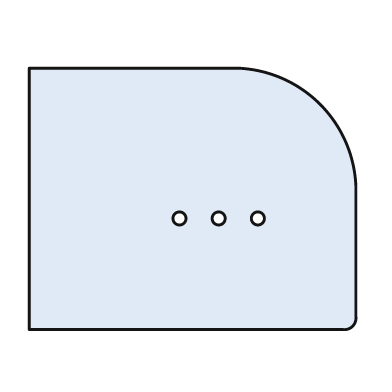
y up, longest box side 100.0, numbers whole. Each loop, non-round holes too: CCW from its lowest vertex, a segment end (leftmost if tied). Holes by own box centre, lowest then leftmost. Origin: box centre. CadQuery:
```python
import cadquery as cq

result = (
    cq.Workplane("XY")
    .moveTo(-50.0, -40.0)
    .lineTo(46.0, -40.0)
    .threePointArc((49.0, -39.0), (50.0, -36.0))
    .lineTo(50.0, 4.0)
    .threePointArc((39.0, 29.0), (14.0, 40.0))
    .lineTo(-50.0, 40.0)
    .close()
    .moveTo(-4.0, -6.0)
    .circle(2.0)
    .moveTo(8.0, -6.0)
    .circle(2.0)
    .moveTo(20.0, -6.0)
    .circle(2.0)
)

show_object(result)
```